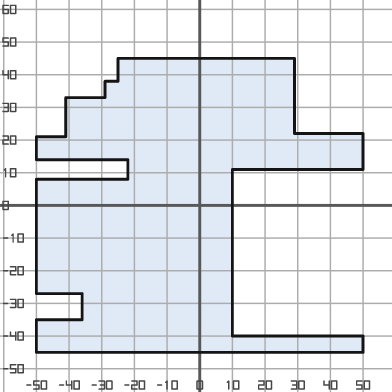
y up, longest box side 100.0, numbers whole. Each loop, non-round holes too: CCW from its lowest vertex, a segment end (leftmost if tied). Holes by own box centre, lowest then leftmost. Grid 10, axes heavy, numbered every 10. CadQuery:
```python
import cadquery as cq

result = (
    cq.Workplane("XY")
    .moveTo(-50.0, -45.0)
    .lineTo(50.0, -45.0)
    .lineTo(50.0, -40.0)
    .lineTo(10.0, -40.0)
    .lineTo(10.0, 11.0)
    .lineTo(50.0, 11.0)
    .lineTo(50.0, 22.0)
    .lineTo(29.0, 22.0)
    .lineTo(29.0, 45.0)
    .lineTo(-25.0, 45.0)
    .lineTo(-25.0, 38.0)
    .lineTo(-29.0, 38.0)
    .lineTo(-29.0, 33.0)
    .lineTo(-41.0, 33.0)
    .lineTo(-41.0, 21.0)
    .lineTo(-50.0, 21.0)
    .lineTo(-50.0, 14.0)
    .lineTo(-22.0, 14.0)
    .lineTo(-22.0, 8.0)
    .lineTo(-50.0, 8.0)
    .lineTo(-50.0, -27.0)
    .lineTo(-36.0, -27.0)
    .lineTo(-36.0, -35.0)
    .lineTo(-50.0, -35.0)
    .close()
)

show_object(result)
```